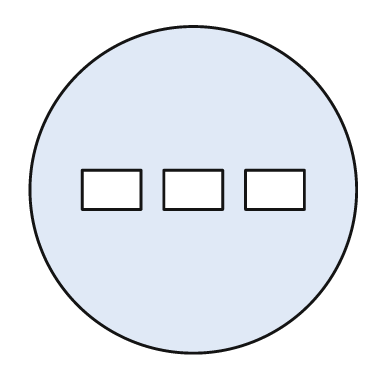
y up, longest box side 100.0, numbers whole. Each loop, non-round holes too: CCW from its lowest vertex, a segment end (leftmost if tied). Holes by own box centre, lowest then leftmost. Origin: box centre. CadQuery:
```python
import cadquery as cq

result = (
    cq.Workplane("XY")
    .moveTo(0.0, 0.0)
    .circle(50.0)
    .moveTo(-34.0, -6.0)
    .lineTo(-16.0, -6.0)
    .lineTo(-16.0, 6.0)
    .lineTo(-34.0, 6.0)
    .close()
    .moveTo(-9.0, -6.0)
    .lineTo(9.0, -6.0)
    .lineTo(9.0, 6.0)
    .lineTo(-9.0, 6.0)
    .close()
    .moveTo(16.0, -6.0)
    .lineTo(34.0, -6.0)
    .lineTo(34.0, 6.0)
    .lineTo(16.0, 6.0)
    .close()
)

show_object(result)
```